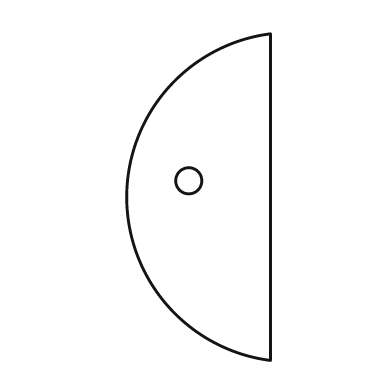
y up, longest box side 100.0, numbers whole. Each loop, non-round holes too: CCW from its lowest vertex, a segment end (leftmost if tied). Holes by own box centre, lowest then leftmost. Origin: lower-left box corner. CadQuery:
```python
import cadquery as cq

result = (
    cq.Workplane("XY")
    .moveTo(44.0, 0.0)
    .lineTo(44.0, 100.0)
    .threePointArc((0.0, 50.0), (44.0, 0.0))
    .close()
    .moveTo(19.0, 55.0)
    .circle(4.0)
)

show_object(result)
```